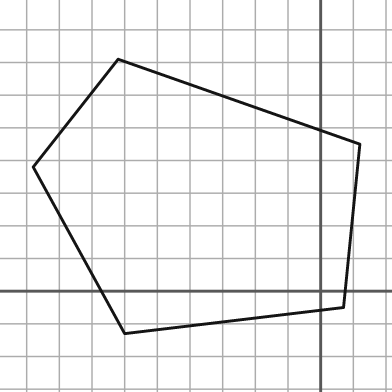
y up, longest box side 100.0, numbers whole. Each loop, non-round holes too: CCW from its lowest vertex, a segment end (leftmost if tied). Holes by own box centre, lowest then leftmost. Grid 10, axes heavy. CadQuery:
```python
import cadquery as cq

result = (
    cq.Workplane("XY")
    .moveTo(-60.0, -13.0)
    .lineTo(7.0, -5.0)
    .lineTo(12.0, 45.0)
    .lineTo(-62.0, 71.0)
    .lineTo(-88.0, 38.0)
    .close()
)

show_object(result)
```